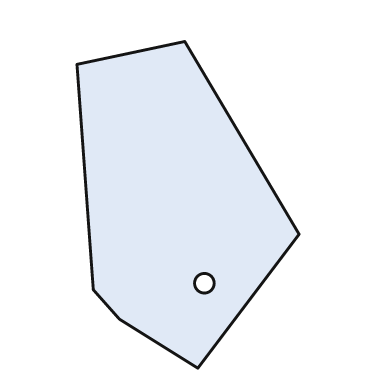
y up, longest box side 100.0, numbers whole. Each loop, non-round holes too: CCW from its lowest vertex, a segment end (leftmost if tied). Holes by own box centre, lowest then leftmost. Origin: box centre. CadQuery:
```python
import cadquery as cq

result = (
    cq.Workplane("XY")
    .moveTo(3.0, -50.0)
    .lineTo(34.0, -9.0)
    .lineTo(-1.0, 50.0)
    .lineTo(-34.0, 43.0)
    .lineTo(-29.0, -26.0)
    .lineTo(-21.0, -35.0)
    .close()
    .moveTo(5.0, -24.0)
    .circle(3.0)
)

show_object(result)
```